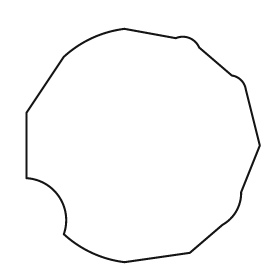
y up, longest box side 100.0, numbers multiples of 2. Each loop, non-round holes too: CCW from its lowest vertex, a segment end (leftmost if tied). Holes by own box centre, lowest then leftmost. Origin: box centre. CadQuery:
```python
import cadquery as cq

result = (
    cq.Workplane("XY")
    .moveTo(-8.0, -50.0)
    .lineTo(20.0, -46.0)
    .lineTo(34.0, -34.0)
    .threePointArc((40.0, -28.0), (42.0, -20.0))
    .lineTo(50.0, 0.0)
    .lineTo(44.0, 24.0)
    .threePointArc((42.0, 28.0), (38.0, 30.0))
    .lineTo(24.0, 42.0)
    .threePointArc((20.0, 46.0), (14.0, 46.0))
    .lineTo(-8.0, 50.0)
    .threePointArc((-22.0, 46.0), (-34.0, 38.0))
    .lineTo(-50.0, 14.0)
    .lineTo(-50.0, -14.0)
    .threePointArc((-36.0, -22.0), (-34.0, -38.0))
    .threePointArc((-22.0, -46.0), (-8.0, -50.0))
    .close()
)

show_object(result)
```